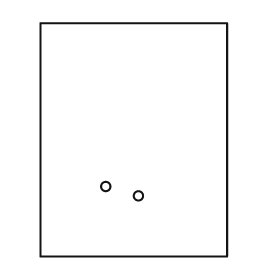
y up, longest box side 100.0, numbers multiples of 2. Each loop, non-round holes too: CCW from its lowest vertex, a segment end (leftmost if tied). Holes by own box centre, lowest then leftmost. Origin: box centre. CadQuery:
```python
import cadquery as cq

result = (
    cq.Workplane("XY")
    .moveTo(-40.0, -50.0)
    .lineTo(40.0, -50.0)
    .lineTo(40.0, 50.0)
    .lineTo(-40.0, 50.0)
    .close()
    .moveTo(2.0, -24.0)
    .circle(2.0)
    .moveTo(-12.0, -20.0)
    .circle(2.0)
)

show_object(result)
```